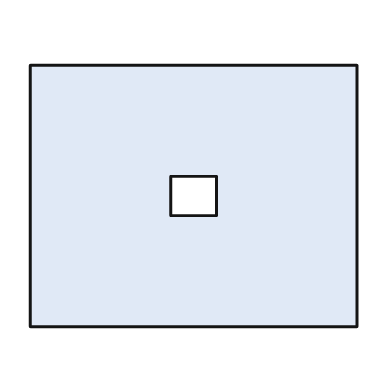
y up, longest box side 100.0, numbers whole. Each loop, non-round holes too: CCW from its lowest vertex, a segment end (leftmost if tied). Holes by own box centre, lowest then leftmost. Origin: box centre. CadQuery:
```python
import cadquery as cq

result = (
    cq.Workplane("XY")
    .moveTo(-50.0, -40.0)
    .lineTo(50.0, -40.0)
    .lineTo(50.0, 40.0)
    .lineTo(-50.0, 40.0)
    .close()
    .moveTo(-7.0, -6.0)
    .lineTo(7.0, -6.0)
    .lineTo(7.0, 6.0)
    .lineTo(-7.0, 6.0)
    .close()
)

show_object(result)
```